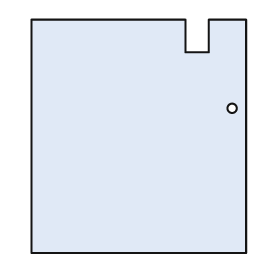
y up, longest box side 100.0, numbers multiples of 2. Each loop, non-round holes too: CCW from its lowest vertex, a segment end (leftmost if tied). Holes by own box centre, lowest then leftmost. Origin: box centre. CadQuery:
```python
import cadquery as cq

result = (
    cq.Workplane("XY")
    .moveTo(-46.0, -50.0)
    .lineTo(46.0, -50.0)
    .lineTo(46.0, 50.0)
    .lineTo(30.0, 50.0)
    .lineTo(30.0, 36.0)
    .lineTo(20.0, 36.0)
    .lineTo(20.0, 50.0)
    .lineTo(-46.0, 50.0)
    .close()
    .moveTo(40.0, 12.0)
    .circle(2.0)
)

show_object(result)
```